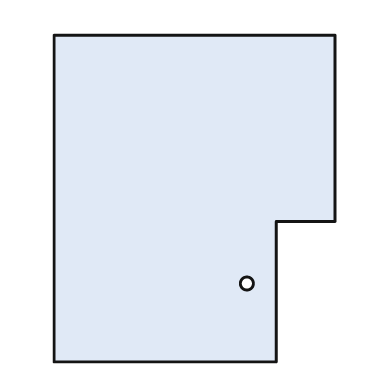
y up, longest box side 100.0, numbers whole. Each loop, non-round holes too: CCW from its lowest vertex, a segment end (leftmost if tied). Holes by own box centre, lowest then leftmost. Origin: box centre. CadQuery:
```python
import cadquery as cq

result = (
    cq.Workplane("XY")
    .moveTo(-43.0, -50.0)
    .lineTo(25.0, -50.0)
    .lineTo(25.0, -7.0)
    .lineTo(43.0, -7.0)
    .lineTo(43.0, 50.0)
    .lineTo(-43.0, 50.0)
    .close()
    .moveTo(16.0, -26.0)
    .circle(2.0)
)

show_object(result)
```